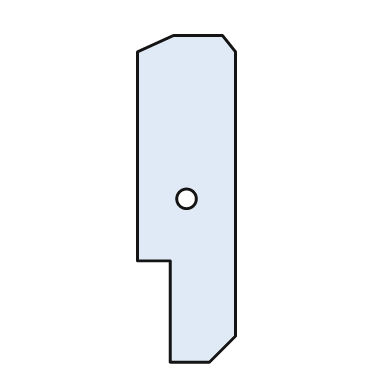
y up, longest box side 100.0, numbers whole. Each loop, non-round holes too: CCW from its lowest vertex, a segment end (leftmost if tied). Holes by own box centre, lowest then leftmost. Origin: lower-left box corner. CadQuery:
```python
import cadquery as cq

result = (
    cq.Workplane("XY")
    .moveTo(10.0, 0.0)
    .lineTo(22.0, 0.0)
    .lineTo(30.0, 8.0)
    .lineTo(30.0, 95.0)
    .lineTo(26.0, 100.0)
    .lineTo(11.0, 100.0)
    .lineTo(0.0, 95.0)
    .lineTo(0.0, 31.0)
    .lineTo(10.0, 31.0)
    .close()
    .moveTo(15.0, 50.0)
    .circle(3.0)
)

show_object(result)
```